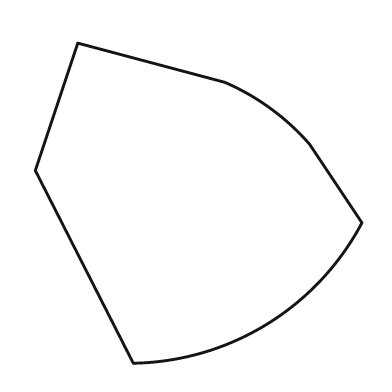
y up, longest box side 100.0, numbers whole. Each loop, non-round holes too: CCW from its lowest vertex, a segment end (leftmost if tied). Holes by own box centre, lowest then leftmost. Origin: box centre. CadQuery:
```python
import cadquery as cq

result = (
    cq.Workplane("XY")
    .moveTo(-20.0, -49.0)
    .threePointArc((21.0, -37.0), (50.0, -6.0))
    .lineTo(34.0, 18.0)
    .threePointArc((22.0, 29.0), (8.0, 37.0))
    .lineTo(-37.0, 49.0)
    .lineTo(-50.0, 10.0)
    .close()
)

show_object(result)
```